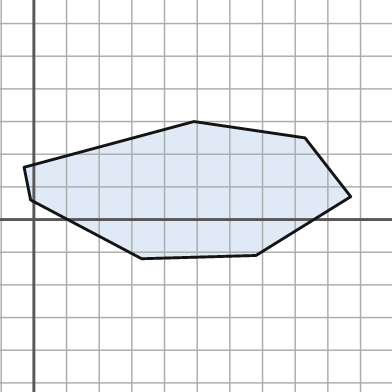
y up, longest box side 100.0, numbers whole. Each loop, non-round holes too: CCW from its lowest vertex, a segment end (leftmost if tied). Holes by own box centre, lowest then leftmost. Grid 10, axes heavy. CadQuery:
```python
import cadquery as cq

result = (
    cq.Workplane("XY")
    .moveTo(33.0, -12.0)
    .lineTo(68.0, -11.0)
    .lineTo(97.0, 7.0)
    .lineTo(83.0, 25.0)
    .lineTo(49.0, 30.0)
    .lineTo(-3.0, 16.0)
    .lineTo(-1.0, 6.0)
    .close()
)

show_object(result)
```